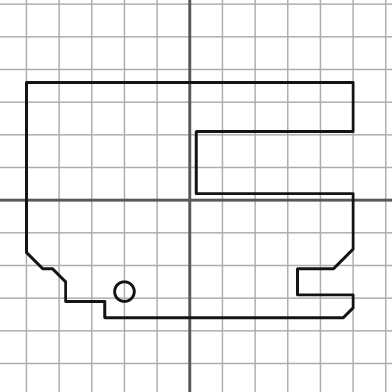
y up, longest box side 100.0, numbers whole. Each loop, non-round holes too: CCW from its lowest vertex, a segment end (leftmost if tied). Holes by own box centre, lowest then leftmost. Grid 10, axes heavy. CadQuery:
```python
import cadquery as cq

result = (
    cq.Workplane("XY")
    .moveTo(-26.0, -36.0)
    .lineTo(47.0, -36.0)
    .lineTo(50.0, -33.0)
    .lineTo(50.0, -29.0)
    .lineTo(33.0, -29.0)
    .lineTo(33.0, -21.0)
    .lineTo(44.0, -21.0)
    .lineTo(50.0, -15.0)
    .lineTo(50.0, 2.0)
    .lineTo(2.0, 2.0)
    .lineTo(2.0, 21.0)
    .lineTo(50.0, 21.0)
    .lineTo(50.0, 36.0)
    .lineTo(-50.0, 36.0)
    .lineTo(-50.0, -16.0)
    .lineTo(-45.0, -21.0)
    .lineTo(-42.0, -21.0)
    .lineTo(-38.0, -25.0)
    .lineTo(-38.0, -31.0)
    .lineTo(-26.0, -31.0)
    .close()
    .moveTo(-20.0, -28.0)
    .circle(3.0)
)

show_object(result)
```